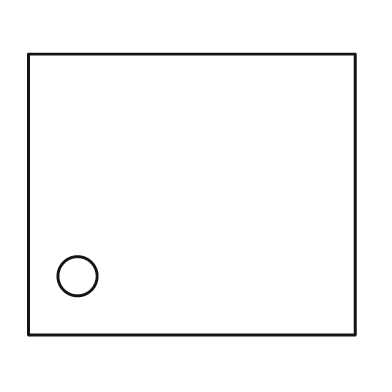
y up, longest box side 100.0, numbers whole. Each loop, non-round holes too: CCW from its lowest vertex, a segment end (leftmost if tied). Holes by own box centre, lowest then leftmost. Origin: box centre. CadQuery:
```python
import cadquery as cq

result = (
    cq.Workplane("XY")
    .moveTo(-50.0, -43.0)
    .lineTo(50.0, -43.0)
    .lineTo(50.0, 43.0)
    .lineTo(-50.0, 43.0)
    .close()
    .moveTo(-35.0, -25.0)
    .circle(6.0)
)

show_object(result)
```